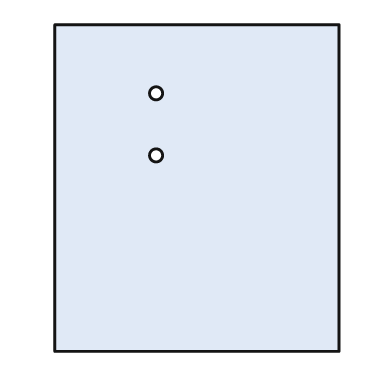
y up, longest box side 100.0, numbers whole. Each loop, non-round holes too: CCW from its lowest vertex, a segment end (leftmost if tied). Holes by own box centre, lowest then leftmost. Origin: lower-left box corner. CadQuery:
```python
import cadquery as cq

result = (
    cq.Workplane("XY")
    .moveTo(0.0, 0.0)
    .lineTo(87.0, 0.0)
    .lineTo(87.0, 100.0)
    .lineTo(0.0, 100.0)
    .close()
    .moveTo(31.0, 60.0)
    .circle(2.0)
    .moveTo(31.0, 79.0)
    .circle(2.0)
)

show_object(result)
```